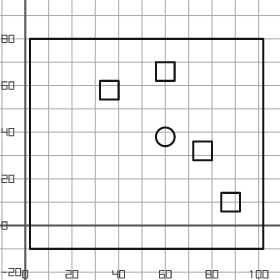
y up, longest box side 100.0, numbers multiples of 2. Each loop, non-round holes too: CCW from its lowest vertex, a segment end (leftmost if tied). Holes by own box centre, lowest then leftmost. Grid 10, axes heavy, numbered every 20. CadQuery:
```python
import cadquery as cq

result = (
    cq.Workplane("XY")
    .moveTo(2.0, -10.0)
    .lineTo(102.0, -10.0)
    .lineTo(102.0, 80.0)
    .lineTo(2.0, 80.0)
    .close()
    .moveTo(84.0, 6.0)
    .lineTo(92.0, 6.0)
    .lineTo(92.0, 14.0)
    .lineTo(84.0, 14.0)
    .close()
    .moveTo(72.0, 28.0)
    .lineTo(80.0, 28.0)
    .lineTo(80.0, 36.0)
    .lineTo(72.0, 36.0)
    .close()
    .moveTo(60.0, 38.0)
    .circle(4.0)
    .moveTo(32.0, 54.0)
    .lineTo(40.0, 54.0)
    .lineTo(40.0, 62.0)
    .lineTo(32.0, 62.0)
    .close()
    .moveTo(56.0, 62.0)
    .lineTo(64.0, 62.0)
    .lineTo(64.0, 70.0)
    .lineTo(56.0, 70.0)
    .close()
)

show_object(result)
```